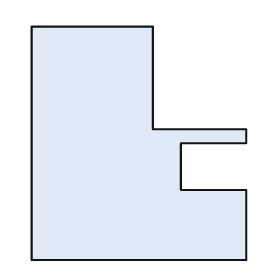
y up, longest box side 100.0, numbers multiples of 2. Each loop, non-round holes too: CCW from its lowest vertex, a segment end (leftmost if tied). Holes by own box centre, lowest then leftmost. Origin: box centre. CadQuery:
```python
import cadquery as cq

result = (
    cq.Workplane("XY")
    .moveTo(-46.0, -50.0)
    .lineTo(46.0, -50.0)
    .lineTo(46.0, -20.0)
    .lineTo(18.0, -20.0)
    .lineTo(18.0, 0.0)
    .lineTo(46.0, 0.0)
    .lineTo(46.0, 6.0)
    .lineTo(6.0, 6.0)
    .lineTo(6.0, 50.0)
    .lineTo(-46.0, 50.0)
    .close()
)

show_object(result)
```